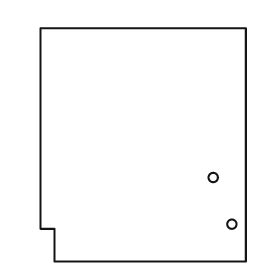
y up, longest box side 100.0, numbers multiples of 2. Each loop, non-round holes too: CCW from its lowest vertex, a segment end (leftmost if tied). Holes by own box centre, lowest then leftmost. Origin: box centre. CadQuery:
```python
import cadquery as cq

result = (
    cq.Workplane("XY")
    .moveTo(-38.0, -50.0)
    .lineTo(44.0, -50.0)
    .lineTo(44.0, 50.0)
    .lineTo(-44.0, 50.0)
    .lineTo(-44.0, -36.0)
    .lineTo(-38.0, -36.0)
    .close()
    .moveTo(38.0, -34.0)
    .circle(2.0)
    .moveTo(30.0, -14.0)
    .circle(2.0)
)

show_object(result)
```